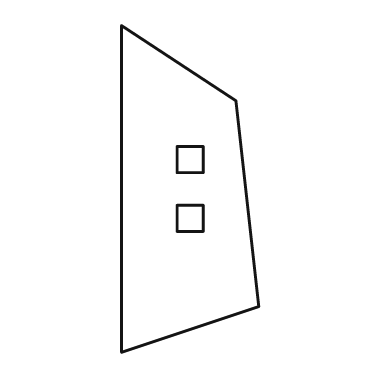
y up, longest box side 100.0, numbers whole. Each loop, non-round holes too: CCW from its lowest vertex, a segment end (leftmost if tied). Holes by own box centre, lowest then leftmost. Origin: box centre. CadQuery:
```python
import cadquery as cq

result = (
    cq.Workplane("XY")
    .moveTo(-21.0, -50.0)
    .lineTo(21.0, -36.0)
    .lineTo(14.0, 27.0)
    .lineTo(-21.0, 50.0)
    .close()
    .moveTo(-4.0, -13.0)
    .lineTo(4.0, -13.0)
    .lineTo(4.0, -5.0)
    .lineTo(-4.0, -5.0)
    .close()
    .moveTo(-4.0, 5.0)
    .lineTo(4.0, 5.0)
    .lineTo(4.0, 13.0)
    .lineTo(-4.0, 13.0)
    .close()
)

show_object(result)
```